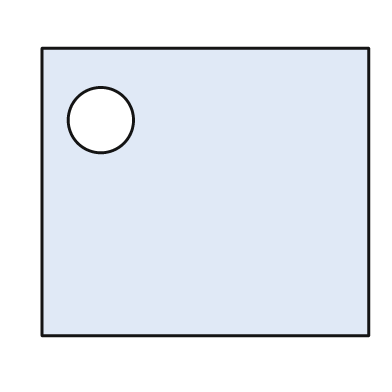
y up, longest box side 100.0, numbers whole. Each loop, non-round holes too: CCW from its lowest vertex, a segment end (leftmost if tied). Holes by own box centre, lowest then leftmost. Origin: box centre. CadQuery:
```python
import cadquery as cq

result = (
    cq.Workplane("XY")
    .moveTo(-50.0, -44.0)
    .lineTo(50.0, -44.0)
    .lineTo(50.0, 44.0)
    .lineTo(-50.0, 44.0)
    .close()
    .moveTo(-32.0, 22.0)
    .circle(10.0)
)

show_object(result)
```